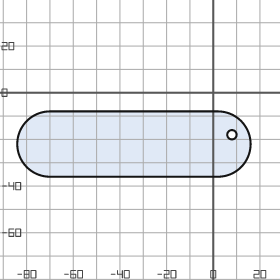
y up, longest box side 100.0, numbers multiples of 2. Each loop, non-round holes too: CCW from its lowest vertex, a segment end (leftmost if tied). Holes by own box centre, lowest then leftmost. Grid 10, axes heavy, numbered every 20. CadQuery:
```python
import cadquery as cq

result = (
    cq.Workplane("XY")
    .moveTo(-70.0, -36.0)
    .lineTo(2.0, -36.0)
    .threePointArc((16.0, -22.0), (2.0, -8.0))
    .lineTo(-70.0, -8.0)
    .threePointArc((-84.0, -22.0), (-70.0, -36.0))
    .close()
    .moveTo(8.0, -18.0)
    .circle(2.0)
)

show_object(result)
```